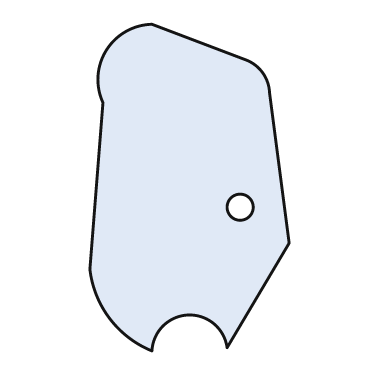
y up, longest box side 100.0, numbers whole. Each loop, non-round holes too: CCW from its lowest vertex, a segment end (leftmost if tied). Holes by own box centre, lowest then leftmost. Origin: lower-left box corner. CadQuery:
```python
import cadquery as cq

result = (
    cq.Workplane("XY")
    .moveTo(19.0, 0.0)
    .threePointArc((30.0, 11.0), (42.0, 1.0))
    .lineTo(61.0, 33.0)
    .lineTo(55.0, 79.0)
    .threePointArc((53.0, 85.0), (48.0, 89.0))
    .lineTo(19.0, 100.0)
    .threePointArc((5.0, 92.0), (4.0, 76.0))
    .lineTo(0.0, 25.0)
    .threePointArc((6.0, 10.0), (19.0, 0.0))
    .close()
    .moveTo(46.0, 44.0)
    .circle(4.0)
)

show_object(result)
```